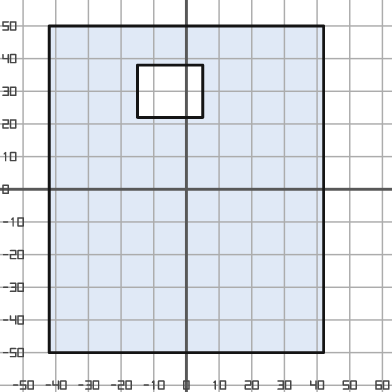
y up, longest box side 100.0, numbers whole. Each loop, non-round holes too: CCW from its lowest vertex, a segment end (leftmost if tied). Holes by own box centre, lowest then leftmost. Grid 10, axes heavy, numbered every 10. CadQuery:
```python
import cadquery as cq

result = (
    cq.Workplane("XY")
    .moveTo(-42.0, -50.0)
    .lineTo(42.0, -50.0)
    .lineTo(42.0, 50.0)
    .lineTo(-42.0, 50.0)
    .close()
    .moveTo(-15.0, 22.0)
    .lineTo(5.0, 22.0)
    .lineTo(5.0, 38.0)
    .lineTo(-15.0, 38.0)
    .close()
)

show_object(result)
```